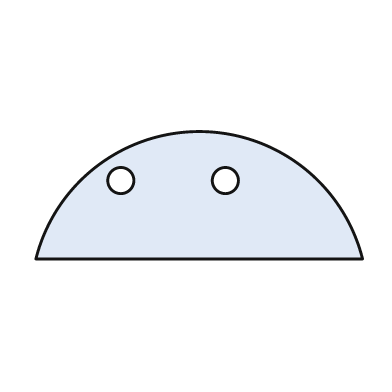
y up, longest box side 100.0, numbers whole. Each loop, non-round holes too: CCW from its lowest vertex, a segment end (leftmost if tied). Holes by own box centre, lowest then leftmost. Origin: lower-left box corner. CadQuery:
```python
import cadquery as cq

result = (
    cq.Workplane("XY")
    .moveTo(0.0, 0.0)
    .lineTo(100.0, 0.0)
    .threePointArc((50.0, 39.0), (0.0, 0.0))
    .close()
    .moveTo(26.0, 24.0)
    .circle(4.0)
    .moveTo(58.0, 24.0)
    .circle(4.0)
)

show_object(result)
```